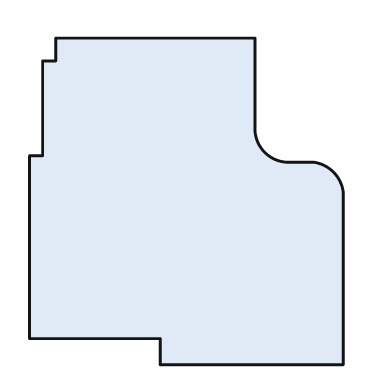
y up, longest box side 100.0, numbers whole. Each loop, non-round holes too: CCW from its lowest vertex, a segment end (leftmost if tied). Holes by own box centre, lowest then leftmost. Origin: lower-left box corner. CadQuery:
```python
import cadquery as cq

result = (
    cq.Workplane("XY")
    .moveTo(40.0, 0.0)
    .lineTo(96.0, 0.0)
    .lineTo(96.0, 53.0)
    .threePointArc((93.0, 59.0), (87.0, 62.0))
    .lineTo(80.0, 62.0)
    .threePointArc((72.0, 65.0), (69.0, 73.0))
    .lineTo(69.0, 100.0)
    .lineTo(8.0, 100.0)
    .lineTo(8.0, 93.0)
    .lineTo(4.0, 93.0)
    .lineTo(4.0, 64.0)
    .lineTo(0.0, 64.0)
    .lineTo(0.0, 8.0)
    .lineTo(40.0, 8.0)
    .close()
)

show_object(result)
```